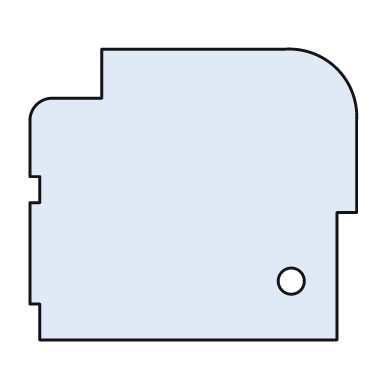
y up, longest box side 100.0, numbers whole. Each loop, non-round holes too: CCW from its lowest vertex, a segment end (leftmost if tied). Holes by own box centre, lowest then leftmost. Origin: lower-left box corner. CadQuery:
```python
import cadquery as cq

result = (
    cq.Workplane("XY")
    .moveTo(3.0, 0.0)
    .lineTo(94.0, 0.0)
    .lineTo(94.0, 39.0)
    .lineTo(100.0, 39.0)
    .lineTo(100.0, 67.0)
    .threePointArc((94.0, 83.0), (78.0, 89.0))
    .lineTo(22.0, 89.0)
    .lineTo(22.0, 74.0)
    .lineTo(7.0, 74.0)
    .threePointArc((2.0, 72.0), (0.0, 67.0))
    .lineTo(0.0, 50.0)
    .lineTo(3.0, 50.0)
    .lineTo(3.0, 42.0)
    .lineTo(0.0, 42.0)
    .lineTo(0.0, 11.0)
    .lineTo(3.0, 11.0)
    .close()
    .moveTo(80.0, 18.0)
    .circle(4.0)
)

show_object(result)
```